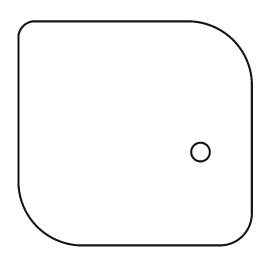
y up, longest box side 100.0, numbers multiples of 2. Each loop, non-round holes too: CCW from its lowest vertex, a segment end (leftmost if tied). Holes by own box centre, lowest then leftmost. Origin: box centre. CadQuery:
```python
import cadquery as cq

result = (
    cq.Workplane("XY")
    .moveTo(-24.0, -48.0)
    .lineTo(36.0, -48.0)
    .threePointArc((46.0, -44.0), (50.0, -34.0))
    .lineTo(50.0, 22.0)
    .threePointArc((42.0, 40.0), (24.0, 48.0))
    .lineTo(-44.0, 48.0)
    .threePointArc((-48.0, 46.0), (-50.0, 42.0))
    .lineTo(-50.0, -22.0)
    .threePointArc((-42.0, -40.0), (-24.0, -48.0))
    .close()
    .moveTo(28.0, -8.0)
    .circle(4.0)
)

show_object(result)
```